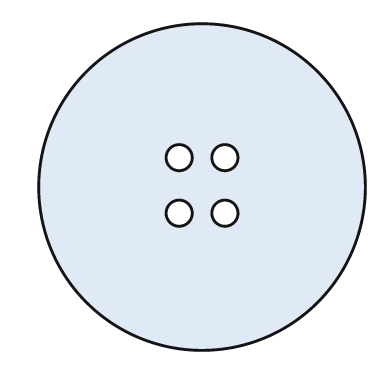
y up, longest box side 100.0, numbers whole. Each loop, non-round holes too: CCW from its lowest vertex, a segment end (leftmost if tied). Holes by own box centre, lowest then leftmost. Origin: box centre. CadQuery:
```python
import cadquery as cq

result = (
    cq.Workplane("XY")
    .moveTo(0.0, 0.0)
    .circle(50.0)
    .moveTo(-7.0, -8.0)
    .circle(4.0)
    .moveTo(7.0, -8.0)
    .circle(4.0)
    .moveTo(-7.0, 9.0)
    .circle(4.0)
    .moveTo(7.0, 9.0)
    .circle(4.0)
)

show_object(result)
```